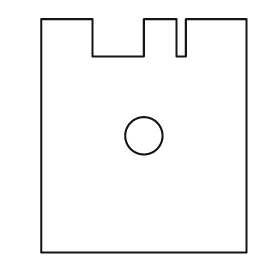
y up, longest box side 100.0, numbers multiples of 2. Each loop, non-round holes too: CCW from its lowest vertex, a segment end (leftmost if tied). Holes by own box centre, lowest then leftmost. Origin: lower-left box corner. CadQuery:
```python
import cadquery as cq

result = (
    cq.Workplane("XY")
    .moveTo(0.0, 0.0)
    .lineTo(88.0, 0.0)
    .lineTo(88.0, 100.0)
    .lineTo(62.0, 100.0)
    .lineTo(62.0, 84.0)
    .lineTo(58.0, 84.0)
    .lineTo(58.0, 100.0)
    .lineTo(44.0, 100.0)
    .lineTo(44.0, 84.0)
    .lineTo(22.0, 84.0)
    .lineTo(22.0, 100.0)
    .lineTo(0.0, 100.0)
    .close()
    .moveTo(44.0, 50.0)
    .circle(8.0)
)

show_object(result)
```